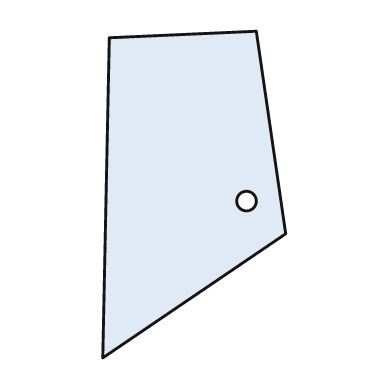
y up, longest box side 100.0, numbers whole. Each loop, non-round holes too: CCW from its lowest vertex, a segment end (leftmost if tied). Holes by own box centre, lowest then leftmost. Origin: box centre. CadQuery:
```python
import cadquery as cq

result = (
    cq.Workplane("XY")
    .moveTo(-28.0, -50.0)
    .lineTo(28.0, -12.0)
    .lineTo(19.0, 50.0)
    .lineTo(-26.0, 48.0)
    .close()
    .moveTo(16.0, -2.0)
    .circle(3.0)
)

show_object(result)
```